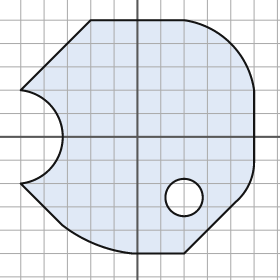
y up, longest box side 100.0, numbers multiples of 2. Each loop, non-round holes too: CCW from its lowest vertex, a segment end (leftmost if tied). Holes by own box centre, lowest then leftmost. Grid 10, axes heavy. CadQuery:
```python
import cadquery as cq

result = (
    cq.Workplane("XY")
    .moveTo(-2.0, -50.0)
    .lineTo(20.0, -50.0)
    .lineTo(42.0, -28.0)
    .threePointArc((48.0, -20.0), (50.0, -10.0))
    .lineTo(50.0, 20.0)
    .threePointArc((40.0, 40.0), (20.0, 50.0))
    .lineTo(-20.0, 50.0)
    .lineTo(-50.0, 20.0)
    .threePointArc((-32.0, 0.0), (-50.0, -20.0))
    .lineTo(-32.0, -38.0)
    .threePointArc((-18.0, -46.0), (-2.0, -50.0))
    .close()
    .moveTo(20.0, -26.0)
    .circle(8.0)
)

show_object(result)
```